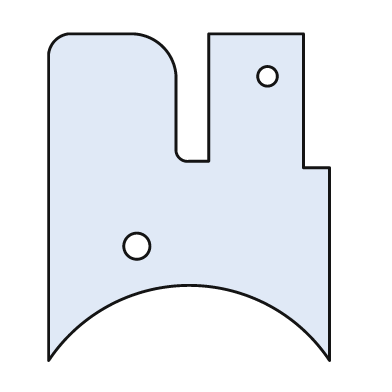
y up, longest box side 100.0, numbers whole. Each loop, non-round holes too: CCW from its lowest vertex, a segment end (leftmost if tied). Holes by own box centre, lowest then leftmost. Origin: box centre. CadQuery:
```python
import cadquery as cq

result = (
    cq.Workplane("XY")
    .moveTo(-43.0, -50.0)
    .threePointArc((0.0, -27.0), (43.0, -50.0))
    .lineTo(43.0, 9.0)
    .lineTo(35.0, 9.0)
    .lineTo(35.0, 50.0)
    .lineTo(6.0, 50.0)
    .lineTo(6.0, 11.0)
    .lineTo(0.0, 11.0)
    .threePointArc((-3.0, 12.0), (-4.0, 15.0))
    .lineTo(-4.0, 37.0)
    .threePointArc((-8.0, 46.0), (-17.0, 50.0))
    .lineTo(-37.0, 50.0)
    .threePointArc((-41.0, 48.0), (-43.0, 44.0))
    .close()
    .moveTo(-16.0, -15.0)
    .circle(4.0)
    .moveTo(24.0, 37.0)
    .circle(3.0)
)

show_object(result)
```